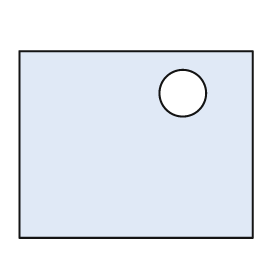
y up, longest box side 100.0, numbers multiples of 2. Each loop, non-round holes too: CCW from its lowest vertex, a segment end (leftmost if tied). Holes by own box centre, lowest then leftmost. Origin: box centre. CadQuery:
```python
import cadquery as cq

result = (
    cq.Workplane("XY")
    .moveTo(-50.0, -40.0)
    .lineTo(50.0, -40.0)
    .lineTo(50.0, 40.0)
    .lineTo(-50.0, 40.0)
    .close()
    .moveTo(20.0, 22.0)
    .circle(10.0)
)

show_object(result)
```